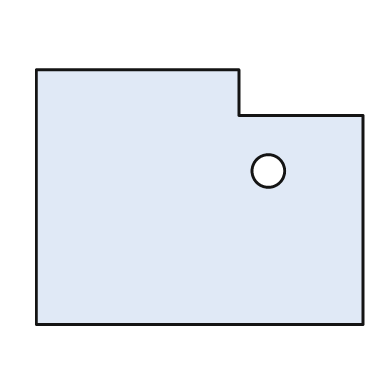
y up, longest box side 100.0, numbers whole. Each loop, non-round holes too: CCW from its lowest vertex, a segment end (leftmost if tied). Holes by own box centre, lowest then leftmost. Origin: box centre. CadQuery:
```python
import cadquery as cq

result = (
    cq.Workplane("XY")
    .moveTo(-50.0, -39.0)
    .lineTo(50.0, -39.0)
    .lineTo(50.0, 25.0)
    .lineTo(12.0, 25.0)
    .lineTo(12.0, 39.0)
    .lineTo(-50.0, 39.0)
    .close()
    .moveTo(21.0, 8.0)
    .circle(5.0)
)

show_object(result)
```